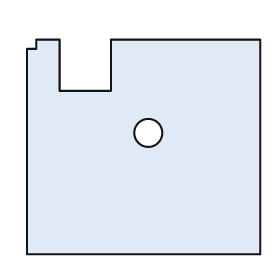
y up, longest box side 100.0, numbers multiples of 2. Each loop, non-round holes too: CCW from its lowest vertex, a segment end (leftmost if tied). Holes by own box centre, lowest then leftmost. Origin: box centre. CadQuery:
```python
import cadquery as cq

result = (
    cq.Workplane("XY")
    .moveTo(-50.0, -46.0)
    .lineTo(50.0, -46.0)
    .lineTo(50.0, 46.0)
    .lineTo(-14.0, 46.0)
    .lineTo(-14.0, 24.0)
    .lineTo(-36.0, 24.0)
    .lineTo(-36.0, 46.0)
    .lineTo(-46.0, 46.0)
    .lineTo(-46.0, 42.0)
    .lineTo(-50.0, 42.0)
    .close()
    .moveTo(2.0, 6.0)
    .circle(6.0)
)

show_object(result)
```